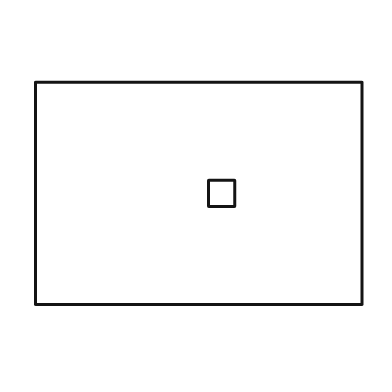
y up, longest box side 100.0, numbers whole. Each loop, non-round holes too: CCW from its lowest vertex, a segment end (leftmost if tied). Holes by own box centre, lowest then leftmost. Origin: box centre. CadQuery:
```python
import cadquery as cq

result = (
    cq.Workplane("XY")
    .moveTo(-50.0, -34.0)
    .lineTo(50.0, -34.0)
    .lineTo(50.0, 34.0)
    .lineTo(-50.0, 34.0)
    .close()
    .moveTo(3.0, -4.0)
    .lineTo(11.0, -4.0)
    .lineTo(11.0, 4.0)
    .lineTo(3.0, 4.0)
    .close()
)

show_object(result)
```